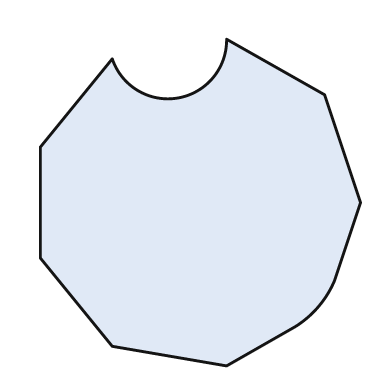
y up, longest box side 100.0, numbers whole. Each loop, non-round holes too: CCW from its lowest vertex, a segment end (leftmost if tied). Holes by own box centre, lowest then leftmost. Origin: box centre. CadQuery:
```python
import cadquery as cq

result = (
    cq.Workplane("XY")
    .moveTo(8.0, -50.0)
    .lineTo(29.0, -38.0)
    .threePointArc((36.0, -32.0), (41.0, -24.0))
    .lineTo(49.0, 0.0)
    .lineTo(38.0, 33.0)
    .lineTo(8.0, 50.0)
    .threePointArc((-7.0, 32.0), (-27.0, 44.0))
    .lineTo(-49.0, 17.0)
    .lineTo(-49.0, -17.0)
    .lineTo(-27.0, -44.0)
    .close()
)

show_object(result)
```